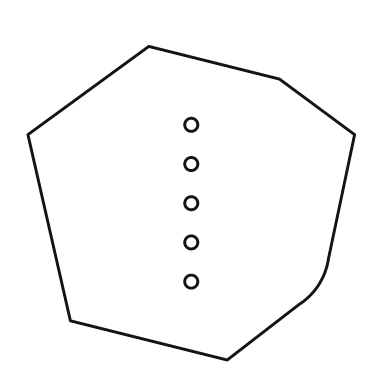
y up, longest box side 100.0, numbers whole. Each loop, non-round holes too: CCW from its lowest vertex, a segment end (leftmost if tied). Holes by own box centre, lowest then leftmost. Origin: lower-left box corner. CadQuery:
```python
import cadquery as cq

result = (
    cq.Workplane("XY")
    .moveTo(61.0, 0.0)
    .lineTo(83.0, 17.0)
    .threePointArc((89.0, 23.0), (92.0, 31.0))
    .lineTo(100.0, 69.0)
    .lineTo(77.0, 86.0)
    .lineTo(37.0, 96.0)
    .lineTo(0.0, 69.0)
    .lineTo(13.0, 12.0)
    .close()
    .moveTo(50.0, 24.0)
    .circle(2.0)
    .moveTo(50.0, 36.0)
    .circle(2.0)
    .moveTo(50.0, 48.0)
    .circle(2.0)
    .moveTo(50.0, 60.0)
    .circle(2.0)
    .moveTo(50.0, 72.0)
    .circle(2.0)
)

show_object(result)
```